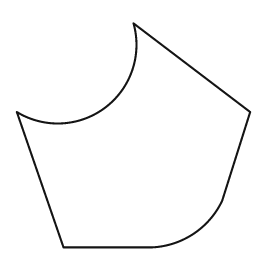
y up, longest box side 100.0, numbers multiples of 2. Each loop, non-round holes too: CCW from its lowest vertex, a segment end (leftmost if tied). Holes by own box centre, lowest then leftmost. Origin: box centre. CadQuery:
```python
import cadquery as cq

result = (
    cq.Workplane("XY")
    .moveTo(-30.0, -48.0)
    .lineTo(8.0, -48.0)
    .threePointArc((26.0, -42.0), (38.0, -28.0))
    .lineTo(50.0, 10.0)
    .lineTo(0.0, 48.0)
    .threePointArc((-12.0, 12.0), (-50.0, 10.0))
    .close()
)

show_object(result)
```